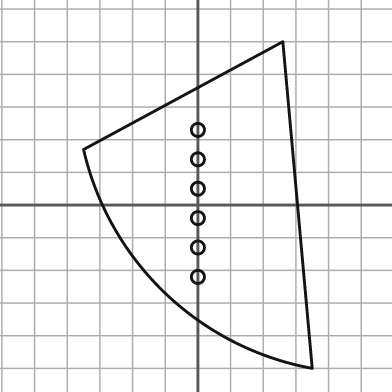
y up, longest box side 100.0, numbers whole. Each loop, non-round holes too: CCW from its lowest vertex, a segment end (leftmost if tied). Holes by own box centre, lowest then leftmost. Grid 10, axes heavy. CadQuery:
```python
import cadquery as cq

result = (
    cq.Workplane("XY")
    .moveTo(35.0, -50.0)
    .lineTo(26.0, 50.0)
    .lineTo(-35.0, 17.0)
    .threePointArc((-10.0, -27.0), (35.0, -50.0))
    .close()
    .moveTo(0.0, -22.0)
    .circle(2.0)
    .moveTo(0.0, -13.0)
    .circle(2.0)
    .moveTo(0.0, -4.0)
    .circle(2.0)
    .moveTo(0.0, 5.0)
    .circle(2.0)
    .moveTo(0.0, 14.0)
    .circle(2.0)
    .moveTo(0.0, 23.0)
    .circle(2.0)
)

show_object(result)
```